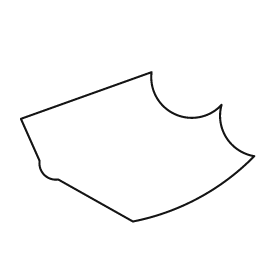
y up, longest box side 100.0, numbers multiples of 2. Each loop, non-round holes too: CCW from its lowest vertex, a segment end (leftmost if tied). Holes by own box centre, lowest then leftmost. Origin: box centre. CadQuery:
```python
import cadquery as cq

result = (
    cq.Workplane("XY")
    .moveTo(-2.0, -32.0)
    .threePointArc((26.0, -22.0), (50.0, -4.0))
    .threePointArc((38.0, 4.0), (36.0, 18.0))
    .threePointArc((16.0, 14.0), (6.0, 32.0))
    .lineTo(-50.0, 12.0)
    .lineTo(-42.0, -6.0)
    .threePointArc((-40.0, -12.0), (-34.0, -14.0))
    .close()
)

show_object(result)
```